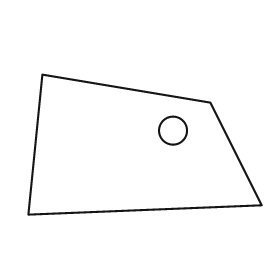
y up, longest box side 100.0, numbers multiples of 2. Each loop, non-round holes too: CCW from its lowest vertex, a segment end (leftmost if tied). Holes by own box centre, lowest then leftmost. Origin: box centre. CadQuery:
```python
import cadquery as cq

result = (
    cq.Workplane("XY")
    .moveTo(-50.0, -30.0)
    .lineTo(50.0, -26.0)
    .lineTo(28.0, 18.0)
    .lineTo(-44.0, 30.0)
    .close()
    .moveTo(12.0, 6.0)
    .circle(6.0)
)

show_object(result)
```